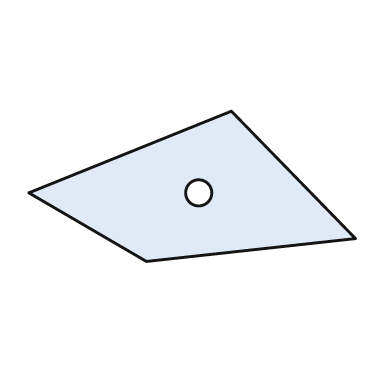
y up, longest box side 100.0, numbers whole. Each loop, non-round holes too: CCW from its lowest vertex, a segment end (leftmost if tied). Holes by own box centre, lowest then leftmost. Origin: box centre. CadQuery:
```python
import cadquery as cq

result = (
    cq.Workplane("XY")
    .moveTo(-14.0, -23.0)
    .lineTo(50.0, -16.0)
    .lineTo(12.0, 23.0)
    .lineTo(-50.0, -2.0)
    .close()
    .moveTo(2.0, -2.0)
    .circle(4.0)
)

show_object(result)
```